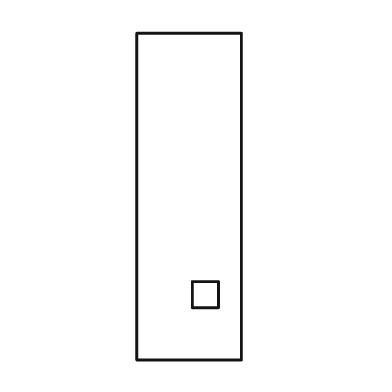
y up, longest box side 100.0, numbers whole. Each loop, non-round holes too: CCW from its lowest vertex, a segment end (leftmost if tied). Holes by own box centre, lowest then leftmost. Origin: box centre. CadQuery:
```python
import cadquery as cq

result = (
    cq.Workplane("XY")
    .moveTo(-16.0, -50.0)
    .lineTo(16.0, -50.0)
    .lineTo(16.0, 50.0)
    .lineTo(-16.0, 50.0)
    .close()
    .moveTo(1.0, -34.0)
    .lineTo(9.0, -34.0)
    .lineTo(9.0, -26.0)
    .lineTo(1.0, -26.0)
    .close()
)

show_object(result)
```